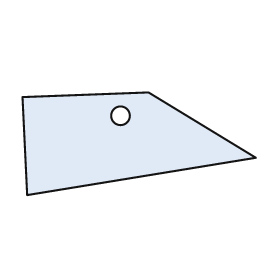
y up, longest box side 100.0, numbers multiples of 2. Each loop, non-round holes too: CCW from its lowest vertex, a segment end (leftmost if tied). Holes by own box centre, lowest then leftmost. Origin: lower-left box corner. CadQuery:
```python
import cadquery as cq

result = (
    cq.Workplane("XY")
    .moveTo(2.0, 0.0)
    .lineTo(100.0, 16.0)
    .lineTo(54.0, 44.0)
    .lineTo(0.0, 42.0)
    .close()
    .moveTo(42.0, 34.0)
    .circle(4.0)
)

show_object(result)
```